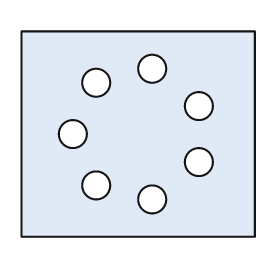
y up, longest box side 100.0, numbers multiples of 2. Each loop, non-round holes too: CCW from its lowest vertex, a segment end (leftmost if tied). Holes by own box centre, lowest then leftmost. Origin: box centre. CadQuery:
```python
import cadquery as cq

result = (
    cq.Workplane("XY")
    .moveTo(-50.0, -44.0)
    .lineTo(50.0, -44.0)
    .lineTo(50.0, 44.0)
    .lineTo(-50.0, 44.0)
    .close()
    .moveTo(6.0, -28.0)
    .circle(6.0)
    .moveTo(-18.0, -22.0)
    .circle(6.0)
    .moveTo(26.0, -12.0)
    .circle(6.0)
    .moveTo(-28.0, 0.0)
    .circle(6.0)
    .moveTo(26.0, 12.0)
    .circle(6.0)
    .moveTo(-18.0, 22.0)
    .circle(6.0)
    .moveTo(6.0, 28.0)
    .circle(6.0)
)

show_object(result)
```